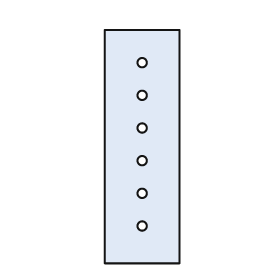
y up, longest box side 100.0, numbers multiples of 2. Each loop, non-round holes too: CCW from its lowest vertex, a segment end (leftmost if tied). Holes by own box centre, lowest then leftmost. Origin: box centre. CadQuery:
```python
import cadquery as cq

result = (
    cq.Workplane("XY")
    .moveTo(-16.0, -50.0)
    .lineTo(16.0, -50.0)
    .lineTo(16.0, 50.0)
    .lineTo(-16.0, 50.0)
    .close()
    .moveTo(0.0, -34.0)
    .circle(2.0)
    .moveTo(0.0, -20.0)
    .circle(2.0)
    .moveTo(0.0, -6.0)
    .circle(2.0)
    .moveTo(0.0, 8.0)
    .circle(2.0)
    .moveTo(0.0, 22.0)
    .circle(2.0)
    .moveTo(0.0, 36.0)
    .circle(2.0)
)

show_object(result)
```